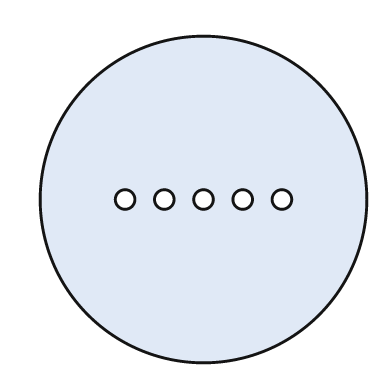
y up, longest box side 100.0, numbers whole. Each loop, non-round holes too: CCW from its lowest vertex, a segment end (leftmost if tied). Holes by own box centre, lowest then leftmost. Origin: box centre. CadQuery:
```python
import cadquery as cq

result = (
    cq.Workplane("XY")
    .moveTo(0.0, 0.0)
    .circle(50.0)
    .moveTo(-24.0, 0.0)
    .circle(3.0)
    .moveTo(-12.0, 0.0)
    .circle(3.0)
    .moveTo(0.0, 0.0)
    .circle(3.0)
    .moveTo(12.0, 0.0)
    .circle(3.0)
    .moveTo(24.0, 0.0)
    .circle(3.0)
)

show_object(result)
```